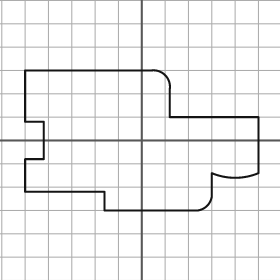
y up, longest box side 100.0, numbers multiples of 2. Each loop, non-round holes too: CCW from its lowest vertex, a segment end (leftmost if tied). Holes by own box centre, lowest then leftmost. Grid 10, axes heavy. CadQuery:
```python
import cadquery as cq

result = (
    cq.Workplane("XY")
    .moveTo(-16.0, -30.0)
    .lineTo(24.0, -30.0)
    .threePointArc((28.0, -28.0), (30.0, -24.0))
    .lineTo(30.0, -14.0)
    .threePointArc((40.0, -16.0), (50.0, -14.0))
    .lineTo(50.0, 10.0)
    .lineTo(12.0, 10.0)
    .lineTo(12.0, 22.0)
    .threePointArc((10.0, 28.0), (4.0, 30.0))
    .lineTo(-50.0, 30.0)
    .lineTo(-50.0, 8.0)
    .lineTo(-42.0, 8.0)
    .lineTo(-42.0, -8.0)
    .lineTo(-50.0, -8.0)
    .lineTo(-50.0, -22.0)
    .lineTo(-16.0, -22.0)
    .close()
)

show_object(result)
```